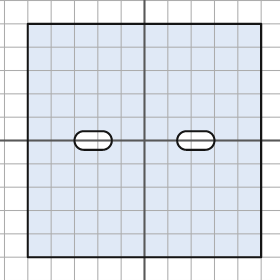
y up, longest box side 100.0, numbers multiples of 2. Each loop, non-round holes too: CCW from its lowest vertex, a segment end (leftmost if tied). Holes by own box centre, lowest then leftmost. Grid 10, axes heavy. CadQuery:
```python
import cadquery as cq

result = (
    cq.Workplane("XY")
    .moveTo(-50.0, -50.0)
    .lineTo(50.0, -50.0)
    .lineTo(50.0, 50.0)
    .lineTo(-50.0, 50.0)
    .close()
    .moveTo(-26.0, -4.0)
    .lineTo(-18.0, -4.0)
    .threePointArc((-14.0, 0.0), (-18.0, 4.0))
    .lineTo(-26.0, 4.0)
    .threePointArc((-30.0, 0.0), (-26.0, -4.0))
    .close()
    .moveTo(18.0, -4.0)
    .lineTo(26.0, -4.0)
    .threePointArc((30.0, 0.0), (26.0, 4.0))
    .lineTo(18.0, 4.0)
    .threePointArc((14.0, 0.0), (18.0, -4.0))
    .close()
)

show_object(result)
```